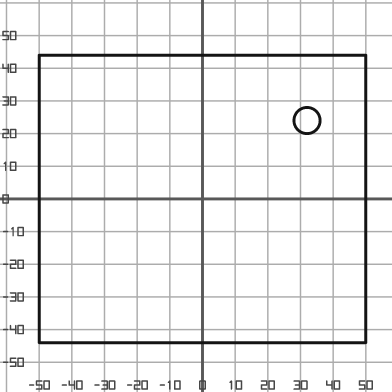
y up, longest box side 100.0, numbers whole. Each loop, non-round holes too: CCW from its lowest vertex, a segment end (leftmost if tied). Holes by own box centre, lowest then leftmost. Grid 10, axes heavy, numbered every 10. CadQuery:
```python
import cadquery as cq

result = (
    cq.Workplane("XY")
    .moveTo(-50.0, -44.0)
    .lineTo(50.0, -44.0)
    .lineTo(50.0, 44.0)
    .lineTo(-50.0, 44.0)
    .close()
    .moveTo(32.0, 24.0)
    .circle(4.0)
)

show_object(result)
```